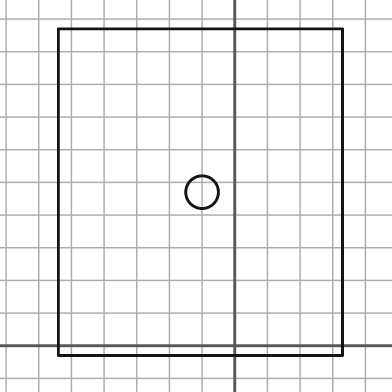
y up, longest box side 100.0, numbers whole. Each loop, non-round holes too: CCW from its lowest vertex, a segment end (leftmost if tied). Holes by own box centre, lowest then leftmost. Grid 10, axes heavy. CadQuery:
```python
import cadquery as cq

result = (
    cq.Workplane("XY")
    .moveTo(-54.0, -3.0)
    .lineTo(33.0, -3.0)
    .lineTo(33.0, 97.0)
    .lineTo(-54.0, 97.0)
    .close()
    .moveTo(-10.0, 47.0)
    .circle(5.0)
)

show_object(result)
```